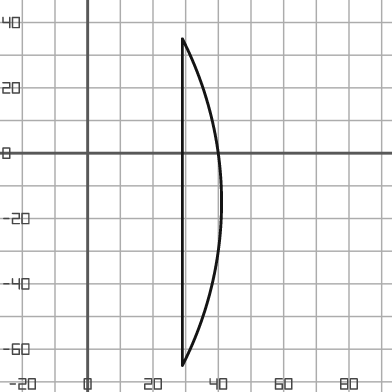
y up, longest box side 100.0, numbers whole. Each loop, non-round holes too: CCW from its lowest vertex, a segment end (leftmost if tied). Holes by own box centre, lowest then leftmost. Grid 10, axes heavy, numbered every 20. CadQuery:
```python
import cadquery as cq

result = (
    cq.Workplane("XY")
    .moveTo(29.0, -65.0)
    .threePointArc((41.0, -15.0), (29.0, 35.0))
    .close()
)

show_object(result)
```